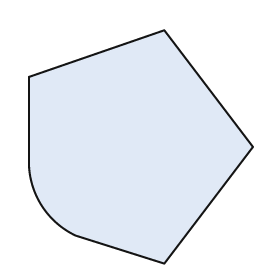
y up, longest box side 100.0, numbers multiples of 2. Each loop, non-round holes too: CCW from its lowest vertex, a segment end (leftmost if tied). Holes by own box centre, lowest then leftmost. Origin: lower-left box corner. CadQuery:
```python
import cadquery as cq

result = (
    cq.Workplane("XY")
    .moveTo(58.0, 0.0)
    .lineTo(96.0, 50.0)
    .lineTo(58.0, 100.0)
    .lineTo(0.0, 80.0)
    .lineTo(0.0, 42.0)
    .threePointArc((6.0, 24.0), (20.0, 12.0))
    .close()
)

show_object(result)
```